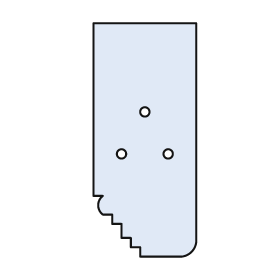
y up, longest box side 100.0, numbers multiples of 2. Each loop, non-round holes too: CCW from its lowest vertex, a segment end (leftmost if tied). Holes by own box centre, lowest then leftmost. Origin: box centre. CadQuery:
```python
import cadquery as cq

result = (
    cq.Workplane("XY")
    .moveTo(-2.0, -50.0)
    .lineTo(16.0, -50.0)
    .threePointArc((20.0, -48.0), (22.0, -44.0))
    .lineTo(22.0, 50.0)
    .lineTo(-22.0, 50.0)
    .lineTo(-22.0, -24.0)
    .lineTo(-18.0, -24.0)
    .threePointArc((-20.0, -28.0), (-18.0, -32.0))
    .lineTo(-14.0, -32.0)
    .lineTo(-14.0, -36.0)
    .lineTo(-10.0, -36.0)
    .lineTo(-10.0, -42.0)
    .lineTo(-6.0, -42.0)
    .lineTo(-6.0, -46.0)
    .lineTo(-2.0, -46.0)
    .close()
    .moveTo(-10.0, -6.0)
    .circle(2.0)
    .moveTo(10.0, -6.0)
    .circle(2.0)
    .moveTo(0.0, 12.0)
    .circle(2.0)
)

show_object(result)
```